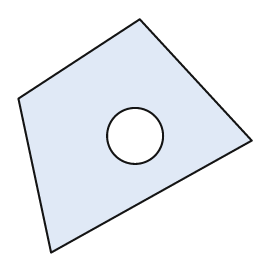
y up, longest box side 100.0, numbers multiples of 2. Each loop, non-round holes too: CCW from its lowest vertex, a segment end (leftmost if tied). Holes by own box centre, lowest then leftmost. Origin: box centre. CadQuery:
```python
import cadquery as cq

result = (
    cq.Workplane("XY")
    .moveTo(-36.0, -50.0)
    .lineTo(50.0, -2.0)
    .lineTo(2.0, 50.0)
    .lineTo(-50.0, 16.0)
    .close()
    .moveTo(0.0, 0.0)
    .circle(12.0)
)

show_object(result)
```